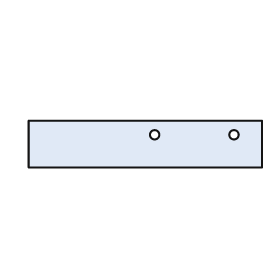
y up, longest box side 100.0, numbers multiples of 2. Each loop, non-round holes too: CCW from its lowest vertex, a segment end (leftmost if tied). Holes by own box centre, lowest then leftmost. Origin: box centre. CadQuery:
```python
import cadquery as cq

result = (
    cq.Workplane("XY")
    .moveTo(-50.0, -10.0)
    .lineTo(50.0, -10.0)
    .lineTo(50.0, 10.0)
    .lineTo(-50.0, 10.0)
    .close()
    .moveTo(4.0, 4.0)
    .circle(2.0)
    .moveTo(38.0, 4.0)
    .circle(2.0)
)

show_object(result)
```